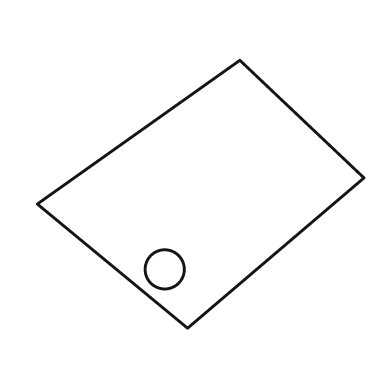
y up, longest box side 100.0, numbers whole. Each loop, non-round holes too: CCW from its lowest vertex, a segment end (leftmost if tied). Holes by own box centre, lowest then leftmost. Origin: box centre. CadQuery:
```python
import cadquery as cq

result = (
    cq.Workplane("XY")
    .moveTo(-4.0, -41.0)
    .lineTo(50.0, 5.0)
    .lineTo(12.0, 41.0)
    .lineTo(-50.0, -3.0)
    .close()
    .moveTo(-11.0, -23.0)
    .circle(6.0)
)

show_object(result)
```